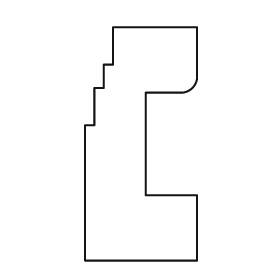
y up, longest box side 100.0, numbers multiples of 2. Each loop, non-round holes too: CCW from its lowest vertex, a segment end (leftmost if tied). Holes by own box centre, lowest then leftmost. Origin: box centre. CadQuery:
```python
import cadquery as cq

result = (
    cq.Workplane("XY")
    .moveTo(-24.0, -50.0)
    .lineTo(24.0, -50.0)
    .lineTo(24.0, -22.0)
    .lineTo(2.0, -22.0)
    .lineTo(2.0, 22.0)
    .lineTo(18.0, 22.0)
    .threePointArc((22.0, 24.0), (24.0, 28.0))
    .lineTo(24.0, 50.0)
    .lineTo(-12.0, 50.0)
    .lineTo(-12.0, 34.0)
    .lineTo(-16.0, 34.0)
    .lineTo(-16.0, 24.0)
    .lineTo(-20.0, 24.0)
    .lineTo(-20.0, 8.0)
    .lineTo(-24.0, 8.0)
    .close()
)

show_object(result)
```